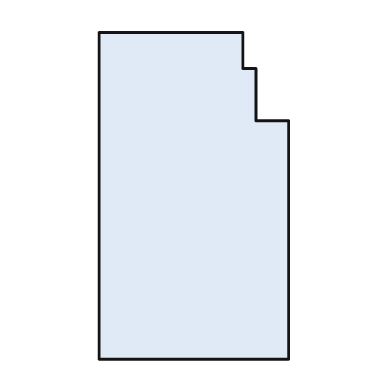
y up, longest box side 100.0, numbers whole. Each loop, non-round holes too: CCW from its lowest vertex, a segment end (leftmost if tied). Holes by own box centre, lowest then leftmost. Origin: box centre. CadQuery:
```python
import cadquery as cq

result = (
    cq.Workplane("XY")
    .moveTo(-29.0, -50.0)
    .lineTo(29.0, -50.0)
    .lineTo(29.0, 23.0)
    .lineTo(19.0, 23.0)
    .lineTo(19.0, 39.0)
    .lineTo(15.0, 39.0)
    .lineTo(15.0, 50.0)
    .lineTo(-29.0, 50.0)
    .close()
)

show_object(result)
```